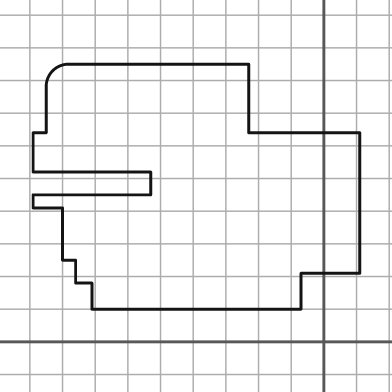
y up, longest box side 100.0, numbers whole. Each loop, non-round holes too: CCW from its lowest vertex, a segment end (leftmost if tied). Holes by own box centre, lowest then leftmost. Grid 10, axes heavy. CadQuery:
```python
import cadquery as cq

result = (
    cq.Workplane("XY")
    .moveTo(-71.0, 10.0)
    .lineTo(-7.0, 10.0)
    .lineTo(-7.0, 21.0)
    .lineTo(11.0, 21.0)
    .lineTo(11.0, 64.0)
    .lineTo(-23.0, 64.0)
    .lineTo(-23.0, 85.0)
    .lineTo(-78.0, 85.0)
    .threePointArc((-83.0, 83.0), (-85.0, 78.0))
    .lineTo(-85.0, 64.0)
    .lineTo(-89.0, 64.0)
    .lineTo(-89.0, 52.0)
    .lineTo(-53.0, 52.0)
    .lineTo(-53.0, 45.0)
    .lineTo(-89.0, 45.0)
    .lineTo(-89.0, 41.0)
    .lineTo(-80.0, 41.0)
    .lineTo(-80.0, 25.0)
    .lineTo(-76.0, 25.0)
    .lineTo(-76.0, 18.0)
    .lineTo(-71.0, 18.0)
    .close()
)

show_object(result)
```